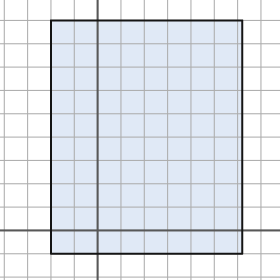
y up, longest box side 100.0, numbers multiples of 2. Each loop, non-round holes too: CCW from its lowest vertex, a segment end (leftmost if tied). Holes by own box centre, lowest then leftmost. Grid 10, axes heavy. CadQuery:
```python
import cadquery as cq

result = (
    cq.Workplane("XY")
    .moveTo(-20.0, -10.0)
    .lineTo(62.0, -10.0)
    .lineTo(62.0, 90.0)
    .lineTo(-20.0, 90.0)
    .close()
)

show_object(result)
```